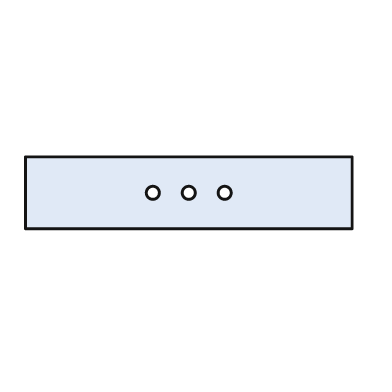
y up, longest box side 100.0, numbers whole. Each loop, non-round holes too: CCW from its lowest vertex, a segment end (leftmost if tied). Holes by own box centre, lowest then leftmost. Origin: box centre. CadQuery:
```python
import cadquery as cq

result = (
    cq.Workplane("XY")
    .moveTo(-50.0, -11.0)
    .lineTo(50.0, -11.0)
    .lineTo(50.0, 11.0)
    .lineTo(-50.0, 11.0)
    .close()
    .moveTo(-11.0, 0.0)
    .circle(2.0)
    .moveTo(0.0, 0.0)
    .circle(2.0)
    .moveTo(11.0, 0.0)
    .circle(2.0)
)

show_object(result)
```